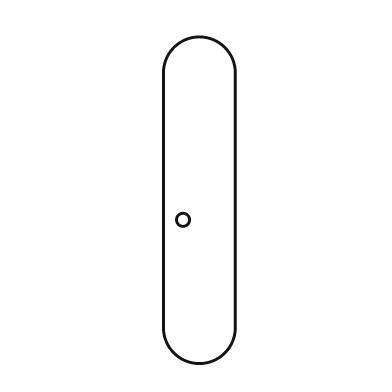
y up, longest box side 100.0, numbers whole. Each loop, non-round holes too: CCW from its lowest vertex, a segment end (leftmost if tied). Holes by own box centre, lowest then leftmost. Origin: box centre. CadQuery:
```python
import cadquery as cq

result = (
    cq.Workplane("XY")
    .moveTo(-11.0, -39.0)
    .threePointArc((0.0, -50.0), (11.0, -39.0))
    .lineTo(11.0, 39.0)
    .threePointArc((0.0, 50.0), (-11.0, 39.0))
    .close()
    .moveTo(-5.0, -6.0)
    .circle(2.0)
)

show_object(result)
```